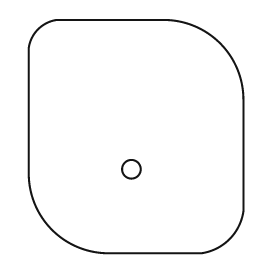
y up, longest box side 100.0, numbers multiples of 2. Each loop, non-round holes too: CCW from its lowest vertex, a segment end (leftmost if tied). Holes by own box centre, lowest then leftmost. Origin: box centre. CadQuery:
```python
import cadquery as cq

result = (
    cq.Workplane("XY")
    .moveTo(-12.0, -50.0)
    .lineTo(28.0, -50.0)
    .threePointArc((40.0, -44.0), (46.0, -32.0))
    .lineTo(46.0, 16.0)
    .threePointArc((36.0, 40.0), (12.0, 50.0))
    .lineTo(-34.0, 50.0)
    .threePointArc((-42.0, 46.0), (-46.0, 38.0))
    .lineTo(-46.0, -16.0)
    .threePointArc((-36.0, -40.0), (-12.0, -50.0))
    .close()
    .moveTo(-2.0, -14.0)
    .circle(4.0)
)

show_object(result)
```